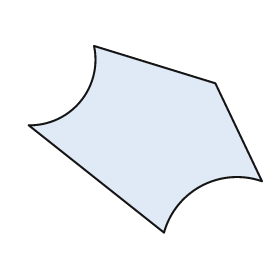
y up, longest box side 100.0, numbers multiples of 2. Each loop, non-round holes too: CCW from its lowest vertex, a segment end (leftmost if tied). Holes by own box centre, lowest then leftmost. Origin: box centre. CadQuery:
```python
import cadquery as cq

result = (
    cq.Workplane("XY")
    .moveTo(8.0, -40.0)
    .threePointArc((24.0, -20.0), (50.0, -18.0))
    .lineTo(30.0, 24.0)
    .lineTo(-22.0, 40.0)
    .threePointArc((-28.0, 16.0), (-50.0, 6.0))
    .close()
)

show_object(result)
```